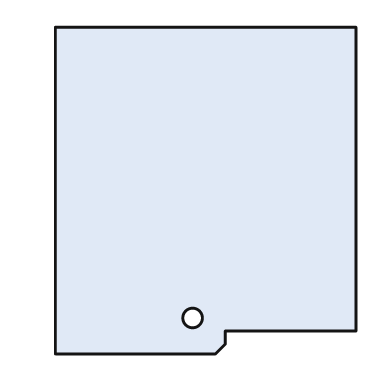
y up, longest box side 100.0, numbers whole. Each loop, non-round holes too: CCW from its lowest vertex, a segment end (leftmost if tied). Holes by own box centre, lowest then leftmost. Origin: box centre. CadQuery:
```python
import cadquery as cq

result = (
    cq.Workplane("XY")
    .moveTo(-46.0, -50.0)
    .lineTo(3.0, -50.0)
    .lineTo(6.0, -47.0)
    .lineTo(6.0, -43.0)
    .lineTo(46.0, -43.0)
    .lineTo(46.0, 50.0)
    .lineTo(-46.0, 50.0)
    .close()
    .moveTo(-4.0, -39.0)
    .circle(3.0)
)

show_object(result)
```